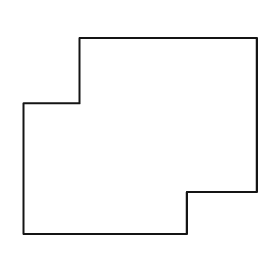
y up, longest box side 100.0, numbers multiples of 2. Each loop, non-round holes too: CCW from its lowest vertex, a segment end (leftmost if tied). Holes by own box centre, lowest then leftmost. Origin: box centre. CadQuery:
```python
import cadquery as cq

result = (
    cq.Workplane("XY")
    .moveTo(-50.0, -42.0)
    .lineTo(20.0, -42.0)
    .lineTo(20.0, -24.0)
    .lineTo(50.0, -24.0)
    .lineTo(50.0, 42.0)
    .lineTo(-26.0, 42.0)
    .lineTo(-26.0, 14.0)
    .lineTo(-50.0, 14.0)
    .close()
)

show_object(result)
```